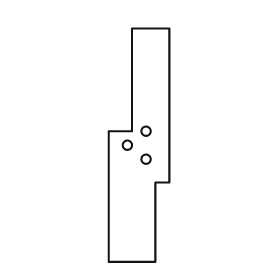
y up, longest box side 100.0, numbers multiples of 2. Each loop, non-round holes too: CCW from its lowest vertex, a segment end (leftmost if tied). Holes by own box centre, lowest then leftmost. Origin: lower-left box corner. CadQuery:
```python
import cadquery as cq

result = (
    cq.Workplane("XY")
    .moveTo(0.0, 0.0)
    .lineTo(20.0, 0.0)
    .lineTo(20.0, 34.0)
    .lineTo(26.0, 34.0)
    .lineTo(26.0, 100.0)
    .lineTo(10.0, 100.0)
    .lineTo(10.0, 56.0)
    .lineTo(0.0, 56.0)
    .close()
    .moveTo(16.0, 44.0)
    .circle(2.0)
    .moveTo(8.0, 50.0)
    .circle(2.0)
    .moveTo(16.0, 56.0)
    .circle(2.0)
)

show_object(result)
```